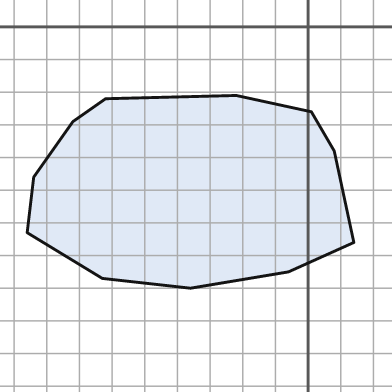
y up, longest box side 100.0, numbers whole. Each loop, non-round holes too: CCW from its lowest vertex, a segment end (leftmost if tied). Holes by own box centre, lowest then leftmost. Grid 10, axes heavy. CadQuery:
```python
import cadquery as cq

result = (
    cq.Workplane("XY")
    .moveTo(-36.0, -80.0)
    .lineTo(-6.0, -75.0)
    .lineTo(14.0, -66.0)
    .lineTo(8.0, -38.0)
    .lineTo(1.0, -26.0)
    .lineTo(-22.0, -21.0)
    .lineTo(-62.0, -22.0)
    .lineTo(-72.0, -29.0)
    .lineTo(-84.0, -46.0)
    .lineTo(-86.0, -63.0)
    .lineTo(-63.0, -77.0)
    .close()
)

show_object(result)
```